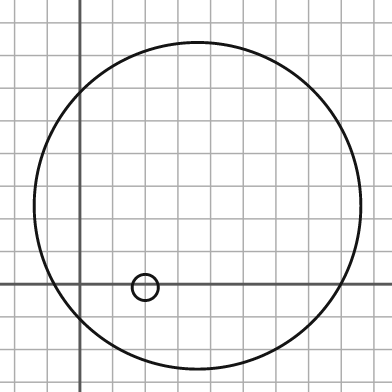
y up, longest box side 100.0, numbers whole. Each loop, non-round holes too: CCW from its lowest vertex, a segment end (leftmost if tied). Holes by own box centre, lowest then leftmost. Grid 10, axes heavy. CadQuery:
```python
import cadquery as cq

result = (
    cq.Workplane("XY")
    .moveTo(36.0, 24.0)
    .circle(50.0)
    .moveTo(20.0, -1.0)
    .circle(4.0)
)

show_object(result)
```